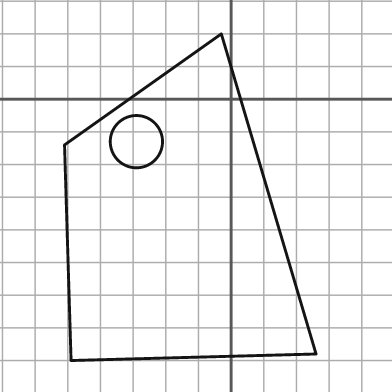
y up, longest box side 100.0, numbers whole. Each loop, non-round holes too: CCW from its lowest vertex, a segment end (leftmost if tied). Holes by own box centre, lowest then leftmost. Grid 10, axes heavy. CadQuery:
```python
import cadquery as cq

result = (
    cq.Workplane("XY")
    .moveTo(-49.0, -80.0)
    .lineTo(26.0, -78.0)
    .lineTo(-3.0, 20.0)
    .lineTo(-51.0, -14.0)
    .close()
    .moveTo(-29.0, -13.0)
    .circle(8.0)
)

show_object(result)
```